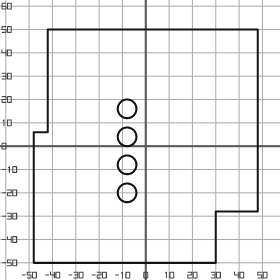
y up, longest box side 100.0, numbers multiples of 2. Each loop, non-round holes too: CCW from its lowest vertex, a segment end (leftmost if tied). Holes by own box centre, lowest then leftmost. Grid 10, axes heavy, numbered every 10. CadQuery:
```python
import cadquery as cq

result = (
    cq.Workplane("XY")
    .moveTo(-48.0, -50.0)
    .lineTo(30.0, -50.0)
    .lineTo(30.0, -28.0)
    .lineTo(48.0, -28.0)
    .lineTo(48.0, 50.0)
    .lineTo(-42.0, 50.0)
    .lineTo(-42.0, 6.0)
    .lineTo(-48.0, 6.0)
    .close()
    .moveTo(-8.0, -20.0)
    .circle(4.0)
    .moveTo(-8.0, -8.0)
    .circle(4.0)
    .moveTo(-8.0, 4.0)
    .circle(4.0)
    .moveTo(-8.0, 16.0)
    .circle(4.0)
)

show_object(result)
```